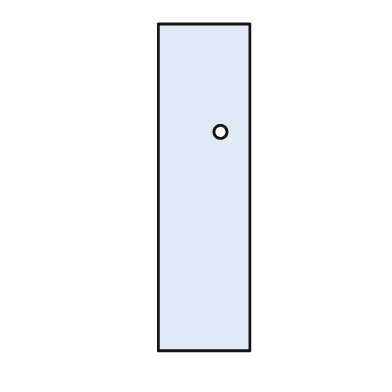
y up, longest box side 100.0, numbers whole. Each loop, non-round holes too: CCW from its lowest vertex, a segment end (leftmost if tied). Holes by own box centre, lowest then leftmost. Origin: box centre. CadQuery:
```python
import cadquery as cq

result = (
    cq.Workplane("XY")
    .moveTo(-14.0, -50.0)
    .lineTo(14.0, -50.0)
    .lineTo(14.0, 50.0)
    .lineTo(-14.0, 50.0)
    .close()
    .moveTo(5.0, 17.0)
    .circle(2.0)
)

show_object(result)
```